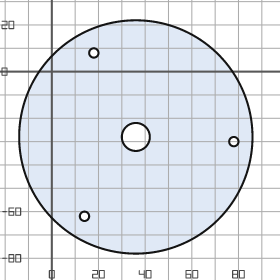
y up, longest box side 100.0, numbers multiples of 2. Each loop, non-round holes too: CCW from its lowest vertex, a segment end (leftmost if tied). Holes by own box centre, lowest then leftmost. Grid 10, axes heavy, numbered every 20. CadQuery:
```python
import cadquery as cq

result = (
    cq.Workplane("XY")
    .moveTo(36.0, -28.0)
    .circle(50.0)
    .moveTo(14.0, -62.0)
    .circle(2.0)
    .moveTo(78.0, -30.0)
    .circle(2.0)
    .moveTo(36.0, -28.0)
    .circle(6.0)
    .moveTo(18.0, 8.0)
    .circle(2.0)
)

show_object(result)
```